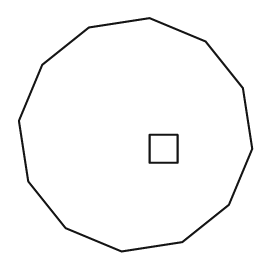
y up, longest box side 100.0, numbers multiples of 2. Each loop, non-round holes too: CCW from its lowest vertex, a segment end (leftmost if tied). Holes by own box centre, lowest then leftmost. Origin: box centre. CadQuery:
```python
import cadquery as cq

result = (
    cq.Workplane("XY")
    .moveTo(-6.0, -50.0)
    .lineTo(20.0, -46.0)
    .lineTo(40.0, -30.0)
    .lineTo(50.0, -6.0)
    .lineTo(46.0, 20.0)
    .lineTo(30.0, 40.0)
    .lineTo(6.0, 50.0)
    .lineTo(-20.0, 46.0)
    .lineTo(-40.0, 30.0)
    .lineTo(-50.0, 6.0)
    .lineTo(-46.0, -20.0)
    .lineTo(-30.0, -40.0)
    .close()
    .moveTo(6.0, -12.0)
    .lineTo(18.0, -12.0)
    .lineTo(18.0, 0.0)
    .lineTo(6.0, 0.0)
    .close()
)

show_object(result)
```